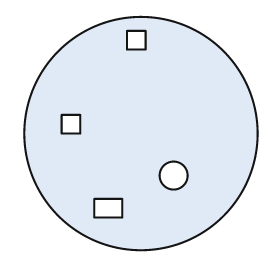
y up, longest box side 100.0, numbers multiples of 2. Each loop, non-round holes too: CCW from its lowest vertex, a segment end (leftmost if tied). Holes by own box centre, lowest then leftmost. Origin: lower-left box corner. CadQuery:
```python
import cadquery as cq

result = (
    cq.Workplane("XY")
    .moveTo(50.0, 50.0)
    .circle(50.0)
    .moveTo(30.0, 14.0)
    .lineTo(42.0, 14.0)
    .lineTo(42.0, 22.0)
    .lineTo(30.0, 22.0)
    .close()
    .moveTo(64.0, 32.0)
    .circle(6.0)
    .moveTo(16.0, 50.0)
    .lineTo(24.0, 50.0)
    .lineTo(24.0, 58.0)
    .lineTo(16.0, 58.0)
    .close()
    .moveTo(44.0, 86.0)
    .lineTo(52.0, 86.0)
    .lineTo(52.0, 94.0)
    .lineTo(44.0, 94.0)
    .close()
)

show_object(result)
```